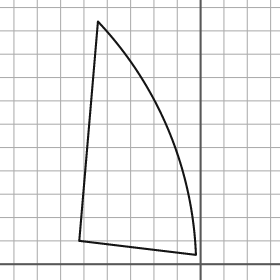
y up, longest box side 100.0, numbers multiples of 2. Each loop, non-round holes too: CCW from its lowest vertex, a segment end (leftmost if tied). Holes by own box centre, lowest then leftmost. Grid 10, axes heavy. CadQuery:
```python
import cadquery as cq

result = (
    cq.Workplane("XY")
    .moveTo(-2.0, 4.0)
    .threePointArc((-14.0, 58.0), (-44.0, 104.0))
    .lineTo(-52.0, 10.0)
    .close()
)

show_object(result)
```